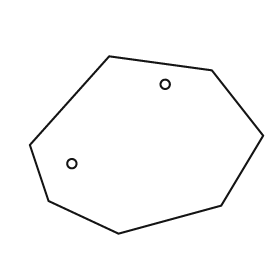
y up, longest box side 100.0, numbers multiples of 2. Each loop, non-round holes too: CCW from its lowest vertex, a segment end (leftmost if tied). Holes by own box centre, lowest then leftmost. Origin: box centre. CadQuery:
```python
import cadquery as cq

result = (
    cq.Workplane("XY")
    .moveTo(-12.0, -38.0)
    .lineTo(32.0, -26.0)
    .lineTo(50.0, 4.0)
    .lineTo(28.0, 32.0)
    .lineTo(-16.0, 38.0)
    .lineTo(-50.0, 0.0)
    .lineTo(-42.0, -24.0)
    .close()
    .moveTo(-32.0, -8.0)
    .circle(2.0)
    .moveTo(8.0, 26.0)
    .circle(2.0)
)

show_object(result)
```